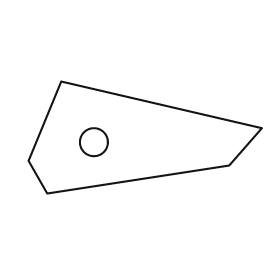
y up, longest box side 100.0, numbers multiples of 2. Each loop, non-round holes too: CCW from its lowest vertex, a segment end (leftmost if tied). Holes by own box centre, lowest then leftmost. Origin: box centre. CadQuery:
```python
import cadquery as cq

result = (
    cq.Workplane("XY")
    .moveTo(-42.0, -24.0)
    .lineTo(36.0, -12.0)
    .lineTo(50.0, 4.0)
    .lineTo(-36.0, 24.0)
    .lineTo(-50.0, -10.0)
    .close()
    .moveTo(-22.0, -2.0)
    .circle(6.0)
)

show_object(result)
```